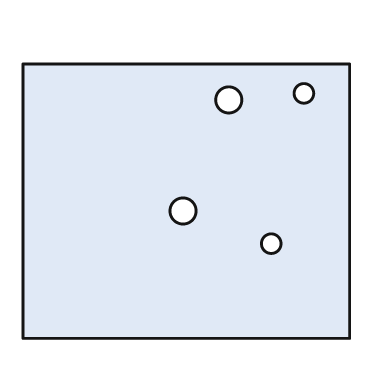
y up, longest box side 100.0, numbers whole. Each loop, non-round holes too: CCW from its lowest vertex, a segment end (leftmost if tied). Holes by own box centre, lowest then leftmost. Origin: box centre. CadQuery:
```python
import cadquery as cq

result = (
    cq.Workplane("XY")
    .moveTo(-50.0, -42.0)
    .lineTo(50.0, -42.0)
    .lineTo(50.0, 42.0)
    .lineTo(-50.0, 42.0)
    .close()
    .moveTo(26.0, -13.0)
    .circle(3.0)
    .moveTo(-1.0, -3.0)
    .circle(4.0)
    .moveTo(13.0, 31.0)
    .circle(4.0)
    .moveTo(36.0, 33.0)
    .circle(3.0)
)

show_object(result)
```